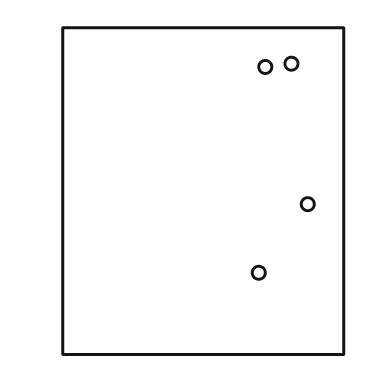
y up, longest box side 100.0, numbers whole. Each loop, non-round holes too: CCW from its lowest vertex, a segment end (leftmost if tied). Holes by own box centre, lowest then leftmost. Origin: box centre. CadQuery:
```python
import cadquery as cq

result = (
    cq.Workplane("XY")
    .moveTo(-43.0, -50.0)
    .lineTo(43.0, -50.0)
    .lineTo(43.0, 50.0)
    .lineTo(-43.0, 50.0)
    .close()
    .moveTo(17.0, -25.0)
    .circle(2.0)
    .moveTo(32.0, -4.0)
    .circle(2.0)
    .moveTo(19.0, 38.0)
    .circle(2.0)
    .moveTo(27.0, 39.0)
    .circle(2.0)
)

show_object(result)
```